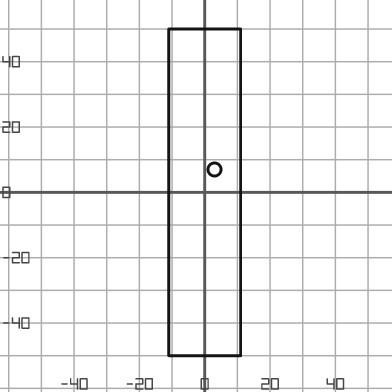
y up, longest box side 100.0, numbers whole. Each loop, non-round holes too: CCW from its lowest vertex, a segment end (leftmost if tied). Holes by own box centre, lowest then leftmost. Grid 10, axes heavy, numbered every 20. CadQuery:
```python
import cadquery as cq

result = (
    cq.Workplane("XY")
    .moveTo(-11.0, -50.0)
    .lineTo(11.0, -50.0)
    .lineTo(11.0, 50.0)
    .lineTo(-11.0, 50.0)
    .close()
    .moveTo(3.0, 7.0)
    .circle(2.0)
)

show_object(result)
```